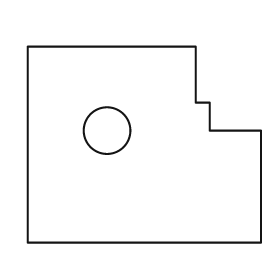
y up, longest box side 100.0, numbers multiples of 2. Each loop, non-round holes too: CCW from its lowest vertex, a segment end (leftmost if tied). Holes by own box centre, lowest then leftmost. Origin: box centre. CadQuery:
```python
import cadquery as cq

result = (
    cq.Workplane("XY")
    .moveTo(-50.0, -42.0)
    .lineTo(50.0, -42.0)
    .lineTo(50.0, 6.0)
    .lineTo(28.0, 6.0)
    .lineTo(28.0, 18.0)
    .lineTo(22.0, 18.0)
    .lineTo(22.0, 42.0)
    .lineTo(-50.0, 42.0)
    .close()
    .moveTo(-16.0, 6.0)
    .circle(10.0)
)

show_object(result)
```